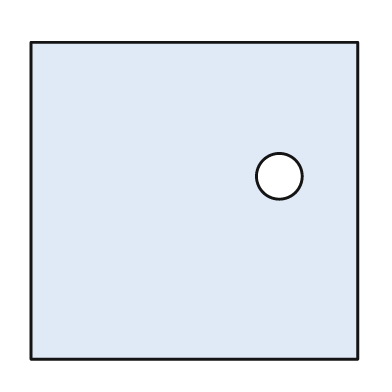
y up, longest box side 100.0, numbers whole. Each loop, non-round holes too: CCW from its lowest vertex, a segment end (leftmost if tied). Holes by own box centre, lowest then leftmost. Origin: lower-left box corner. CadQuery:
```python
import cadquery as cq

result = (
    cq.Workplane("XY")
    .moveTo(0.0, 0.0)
    .lineTo(100.0, 0.0)
    .lineTo(100.0, 97.0)
    .lineTo(0.0, 97.0)
    .close()
    .moveTo(76.0, 56.0)
    .circle(7.0)
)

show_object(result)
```